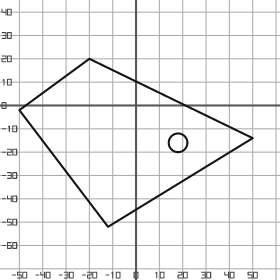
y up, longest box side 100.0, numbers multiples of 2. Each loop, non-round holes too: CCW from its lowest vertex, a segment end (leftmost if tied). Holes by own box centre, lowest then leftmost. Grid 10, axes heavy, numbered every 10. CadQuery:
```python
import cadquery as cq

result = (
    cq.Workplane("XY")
    .moveTo(-12.0, -52.0)
    .lineTo(50.0, -14.0)
    .lineTo(-20.0, 20.0)
    .lineTo(-50.0, -2.0)
    .close()
    .moveTo(18.0, -16.0)
    .circle(4.0)
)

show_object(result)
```